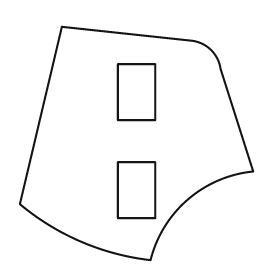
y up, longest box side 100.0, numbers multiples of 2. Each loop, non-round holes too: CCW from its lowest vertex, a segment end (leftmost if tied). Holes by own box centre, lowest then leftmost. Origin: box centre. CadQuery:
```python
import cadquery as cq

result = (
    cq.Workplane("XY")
    .moveTo(6.0, -50.0)
    .threePointArc((22.0, -24.0), (50.0, -12.0))
    .lineTo(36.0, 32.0)
    .threePointArc((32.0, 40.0), (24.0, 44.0))
    .lineTo(-32.0, 50.0)
    .lineTo(-50.0, -26.0)
    .threePointArc((-24.0, -42.0), (6.0, -50.0))
    .close()
    .moveTo(-8.0, -32.0)
    .lineTo(8.0, -32.0)
    .lineTo(8.0, -8.0)
    .lineTo(-8.0, -8.0)
    .close()
    .moveTo(-8.0, 10.0)
    .lineTo(8.0, 10.0)
    .lineTo(8.0, 34.0)
    .lineTo(-8.0, 34.0)
    .close()
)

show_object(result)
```